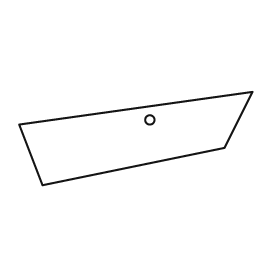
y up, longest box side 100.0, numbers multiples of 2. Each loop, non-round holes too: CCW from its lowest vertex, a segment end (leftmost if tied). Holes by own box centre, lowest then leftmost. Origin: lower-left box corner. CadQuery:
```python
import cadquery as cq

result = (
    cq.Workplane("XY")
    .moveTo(10.0, 0.0)
    .lineTo(88.0, 16.0)
    .lineTo(100.0, 40.0)
    .lineTo(0.0, 26.0)
    .close()
    .moveTo(56.0, 28.0)
    .circle(2.0)
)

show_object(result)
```